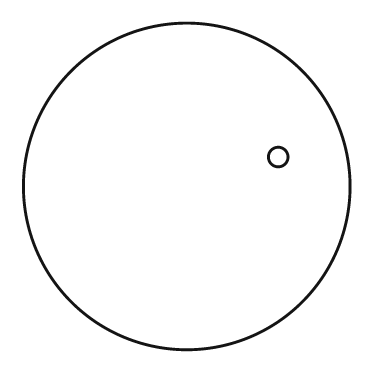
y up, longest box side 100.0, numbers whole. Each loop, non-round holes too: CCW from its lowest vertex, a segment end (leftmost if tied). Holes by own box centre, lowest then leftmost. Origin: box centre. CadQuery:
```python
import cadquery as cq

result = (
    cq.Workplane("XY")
    .moveTo(0.0, 0.0)
    .circle(50.0)
    .moveTo(28.0, 9.0)
    .circle(3.0)
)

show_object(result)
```